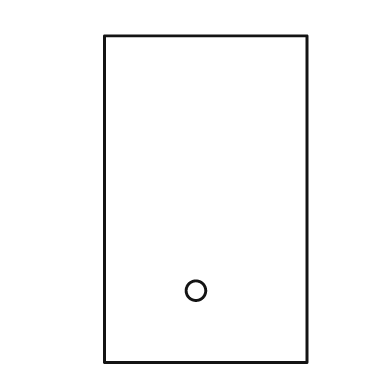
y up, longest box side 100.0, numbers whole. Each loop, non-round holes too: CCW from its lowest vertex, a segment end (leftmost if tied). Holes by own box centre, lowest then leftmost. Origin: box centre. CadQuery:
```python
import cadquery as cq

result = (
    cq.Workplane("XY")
    .moveTo(-31.0, -50.0)
    .lineTo(31.0, -50.0)
    .lineTo(31.0, 50.0)
    .lineTo(-31.0, 50.0)
    .close()
    .moveTo(-3.0, -28.0)
    .circle(3.0)
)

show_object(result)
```